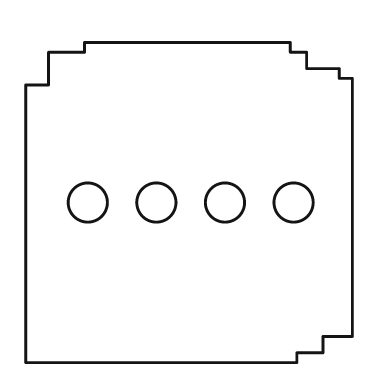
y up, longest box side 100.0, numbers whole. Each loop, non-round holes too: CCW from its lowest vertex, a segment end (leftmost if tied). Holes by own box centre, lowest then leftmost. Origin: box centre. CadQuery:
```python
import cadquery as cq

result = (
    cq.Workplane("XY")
    .moveTo(-50.0, -49.0)
    .lineTo(33.0, -49.0)
    .lineTo(33.0, -46.0)
    .lineTo(41.0, -46.0)
    .lineTo(41.0, -41.0)
    .lineTo(50.0, -41.0)
    .lineTo(50.0, 38.0)
    .lineTo(46.0, 38.0)
    .lineTo(46.0, 41.0)
    .lineTo(36.0, 41.0)
    .lineTo(36.0, 46.0)
    .lineTo(31.0, 46.0)
    .lineTo(31.0, 49.0)
    .lineTo(-32.0, 49.0)
    .lineTo(-32.0, 46.0)
    .lineTo(-43.0, 46.0)
    .lineTo(-43.0, 36.0)
    .lineTo(-50.0, 36.0)
    .close()
    .moveTo(-31.0, 0.0)
    .circle(6.0)
    .moveTo(-10.0, 0.0)
    .circle(6.0)
    .moveTo(11.0, 0.0)
    .circle(6.0)
    .moveTo(32.0, 0.0)
    .circle(6.0)
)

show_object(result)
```